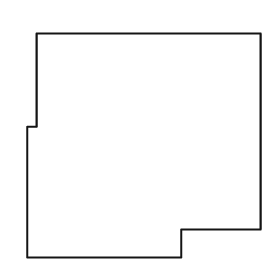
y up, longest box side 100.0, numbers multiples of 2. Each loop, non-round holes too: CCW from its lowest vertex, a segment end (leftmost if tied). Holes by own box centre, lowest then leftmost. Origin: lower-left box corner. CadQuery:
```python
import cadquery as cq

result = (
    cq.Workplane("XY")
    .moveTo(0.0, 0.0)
    .lineTo(66.0, 0.0)
    .lineTo(66.0, 12.0)
    .lineTo(100.0, 12.0)
    .lineTo(100.0, 96.0)
    .lineTo(4.0, 96.0)
    .lineTo(4.0, 56.0)
    .lineTo(0.0, 56.0)
    .close()
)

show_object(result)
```